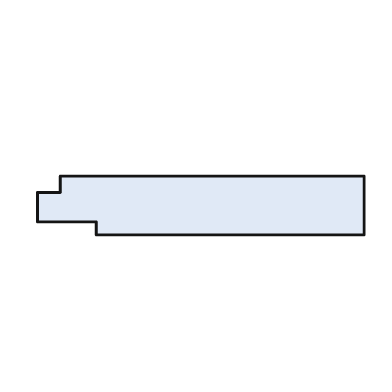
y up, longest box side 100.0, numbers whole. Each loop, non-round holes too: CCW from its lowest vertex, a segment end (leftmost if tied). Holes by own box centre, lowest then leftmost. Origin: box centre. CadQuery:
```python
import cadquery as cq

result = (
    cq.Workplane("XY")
    .moveTo(-32.0, -9.0)
    .lineTo(50.0, -9.0)
    .lineTo(50.0, 9.0)
    .lineTo(-43.0, 9.0)
    .lineTo(-43.0, 4.0)
    .lineTo(-50.0, 4.0)
    .lineTo(-50.0, -5.0)
    .lineTo(-32.0, -5.0)
    .close()
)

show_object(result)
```